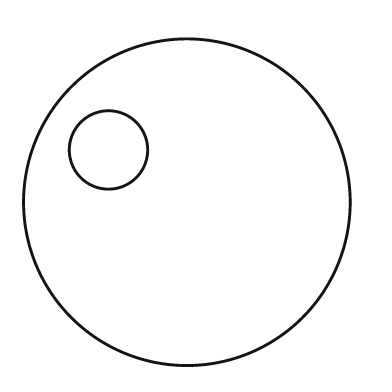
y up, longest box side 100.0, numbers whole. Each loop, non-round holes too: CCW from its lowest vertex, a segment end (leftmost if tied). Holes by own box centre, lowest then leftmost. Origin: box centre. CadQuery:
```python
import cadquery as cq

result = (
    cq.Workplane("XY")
    .moveTo(0.0, 0.0)
    .circle(50.0)
    .moveTo(-24.0, 16.0)
    .circle(12.0)
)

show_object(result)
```